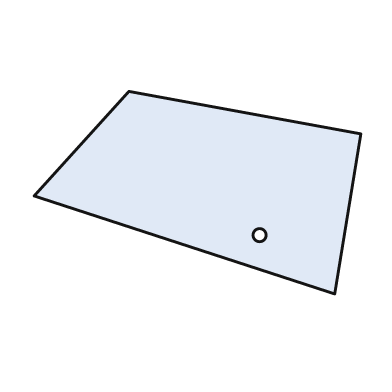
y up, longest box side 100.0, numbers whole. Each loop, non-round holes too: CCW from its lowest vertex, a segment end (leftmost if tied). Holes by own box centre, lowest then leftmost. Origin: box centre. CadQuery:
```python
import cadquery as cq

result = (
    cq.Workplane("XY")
    .moveTo(42.0, -31.0)
    .lineTo(50.0, 18.0)
    .lineTo(-21.0, 31.0)
    .lineTo(-50.0, -1.0)
    .close()
    .moveTo(19.0, -13.0)
    .circle(2.0)
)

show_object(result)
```